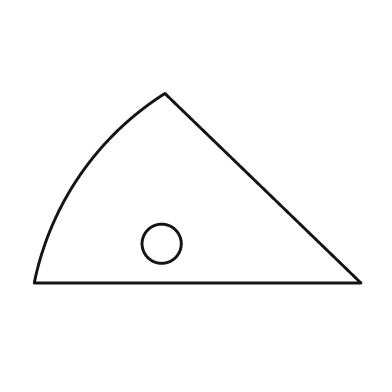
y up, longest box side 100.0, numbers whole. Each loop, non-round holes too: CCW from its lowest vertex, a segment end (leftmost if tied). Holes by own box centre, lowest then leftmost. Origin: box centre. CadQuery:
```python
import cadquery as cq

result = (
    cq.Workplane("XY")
    .moveTo(-50.0, -29.0)
    .lineTo(50.0, -29.0)
    .lineTo(-10.0, 29.0)
    .threePointArc((-36.0, 4.0), (-50.0, -29.0))
    .close()
    .moveTo(-11.0, -17.0)
    .circle(6.0)
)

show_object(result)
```